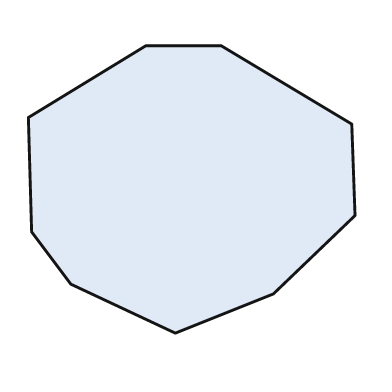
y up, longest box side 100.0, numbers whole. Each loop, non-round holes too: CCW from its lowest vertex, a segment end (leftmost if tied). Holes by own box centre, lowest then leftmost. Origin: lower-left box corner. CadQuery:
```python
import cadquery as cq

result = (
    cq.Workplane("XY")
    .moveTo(45.0, 0.0)
    .lineTo(75.0, 12.0)
    .lineTo(100.0, 36.0)
    .lineTo(99.0, 64.0)
    .lineTo(59.0, 88.0)
    .lineTo(36.0, 88.0)
    .lineTo(0.0, 66.0)
    .lineTo(1.0, 31.0)
    .lineTo(13.0, 15.0)
    .close()
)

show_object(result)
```